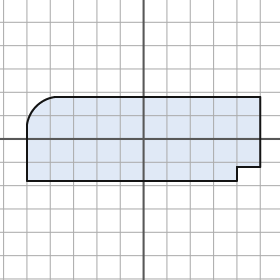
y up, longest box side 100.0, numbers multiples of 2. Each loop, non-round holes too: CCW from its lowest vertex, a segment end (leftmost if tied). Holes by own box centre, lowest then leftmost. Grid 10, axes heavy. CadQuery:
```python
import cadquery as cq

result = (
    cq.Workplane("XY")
    .moveTo(-50.0, -18.0)
    .lineTo(40.0, -18.0)
    .lineTo(40.0, -12.0)
    .lineTo(50.0, -12.0)
    .lineTo(50.0, 18.0)
    .lineTo(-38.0, 18.0)
    .threePointArc((-46.0, 14.0), (-50.0, 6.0))
    .close()
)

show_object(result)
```